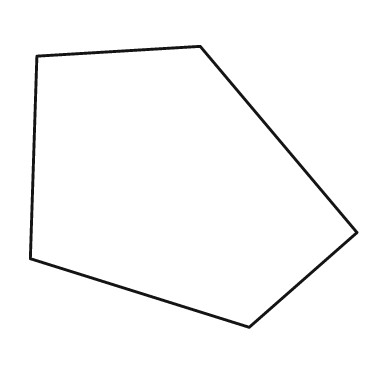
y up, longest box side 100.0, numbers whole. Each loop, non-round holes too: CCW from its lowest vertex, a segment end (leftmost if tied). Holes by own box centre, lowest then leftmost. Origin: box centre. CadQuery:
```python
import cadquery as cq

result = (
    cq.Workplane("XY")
    .moveTo(17.0, -43.0)
    .lineTo(50.0, -14.0)
    .lineTo(2.0, 43.0)
    .lineTo(-48.0, 40.0)
    .lineTo(-50.0, -22.0)
    .close()
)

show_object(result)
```